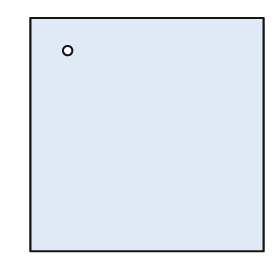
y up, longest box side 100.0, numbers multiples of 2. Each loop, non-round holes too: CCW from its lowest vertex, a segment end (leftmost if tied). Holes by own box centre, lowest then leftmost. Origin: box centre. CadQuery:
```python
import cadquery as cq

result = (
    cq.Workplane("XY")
    .moveTo(-50.0, -50.0)
    .lineTo(50.0, -50.0)
    .lineTo(50.0, 50.0)
    .lineTo(-50.0, 50.0)
    .close()
    .moveTo(-34.0, 36.0)
    .circle(2.0)
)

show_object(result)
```